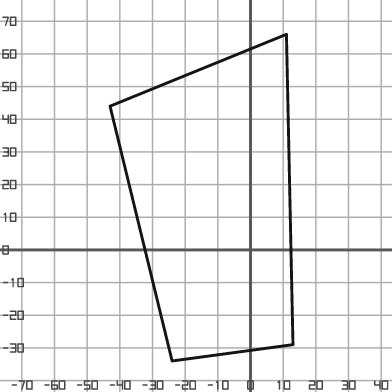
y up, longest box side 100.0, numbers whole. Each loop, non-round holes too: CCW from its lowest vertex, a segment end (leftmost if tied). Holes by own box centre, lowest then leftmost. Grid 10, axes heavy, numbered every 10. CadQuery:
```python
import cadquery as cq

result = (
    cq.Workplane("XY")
    .moveTo(-24.0, -34.0)
    .lineTo(13.0, -29.0)
    .lineTo(11.0, 66.0)
    .lineTo(-43.0, 44.0)
    .close()
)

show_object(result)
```